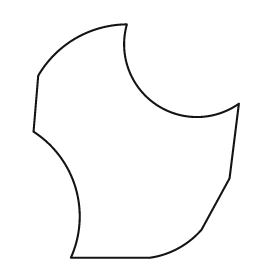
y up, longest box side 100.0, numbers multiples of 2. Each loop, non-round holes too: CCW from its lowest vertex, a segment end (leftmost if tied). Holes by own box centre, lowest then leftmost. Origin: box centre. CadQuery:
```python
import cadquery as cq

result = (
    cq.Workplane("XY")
    .moveTo(-28.0, -50.0)
    .lineTo(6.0, -50.0)
    .threePointArc((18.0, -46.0), (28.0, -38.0))
    .lineTo(40.0, -16.0)
    .lineTo(44.0, 16.0)
    .threePointArc((8.0, 16.0), (-4.0, 50.0))
    .threePointArc((-26.0, 44.0), (-42.0, 28.0))
    .lineTo(-44.0, 4.0)
    .threePointArc((-26.0, -20.0), (-28.0, -50.0))
    .close()
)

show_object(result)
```